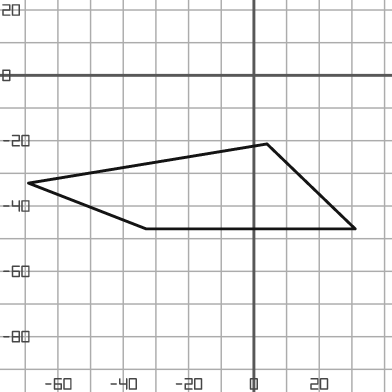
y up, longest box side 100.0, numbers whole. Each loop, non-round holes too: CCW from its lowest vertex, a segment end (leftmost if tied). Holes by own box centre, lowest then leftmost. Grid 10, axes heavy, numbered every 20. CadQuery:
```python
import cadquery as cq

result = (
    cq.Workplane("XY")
    .moveTo(-33.0, -47.0)
    .lineTo(31.0, -47.0)
    .lineTo(4.0, -21.0)
    .lineTo(-69.0, -33.0)
    .close()
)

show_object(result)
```